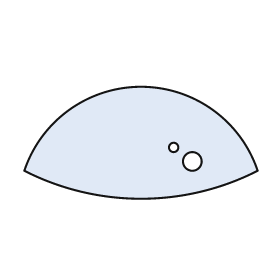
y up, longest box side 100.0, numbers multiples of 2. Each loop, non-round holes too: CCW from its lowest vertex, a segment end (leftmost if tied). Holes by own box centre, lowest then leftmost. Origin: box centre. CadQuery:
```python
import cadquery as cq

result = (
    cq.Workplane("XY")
    .moveTo(-50.0, -12.0)
    .threePointArc((0.0, -24.0), (50.0, -12.0))
    .threePointArc((0.0, 24.0), (-50.0, -12.0))
    .close()
    .moveTo(22.0, -8.0)
    .circle(4.0)
    .moveTo(14.0, -2.0)
    .circle(2.0)
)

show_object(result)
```